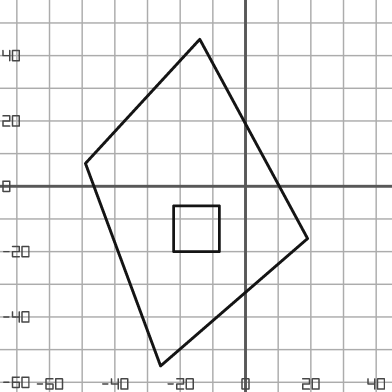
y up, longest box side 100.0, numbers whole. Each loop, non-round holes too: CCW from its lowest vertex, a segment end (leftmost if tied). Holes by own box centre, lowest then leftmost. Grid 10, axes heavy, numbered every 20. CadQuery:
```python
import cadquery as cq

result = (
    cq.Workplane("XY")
    .moveTo(-26.0, -55.0)
    .lineTo(19.0, -16.0)
    .lineTo(-14.0, 45.0)
    .lineTo(-49.0, 7.0)
    .close()
    .moveTo(-22.0, -20.0)
    .lineTo(-8.0, -20.0)
    .lineTo(-8.0, -6.0)
    .lineTo(-22.0, -6.0)
    .close()
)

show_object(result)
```